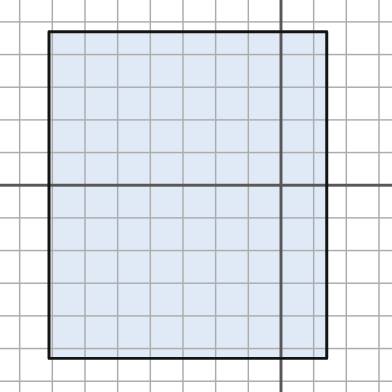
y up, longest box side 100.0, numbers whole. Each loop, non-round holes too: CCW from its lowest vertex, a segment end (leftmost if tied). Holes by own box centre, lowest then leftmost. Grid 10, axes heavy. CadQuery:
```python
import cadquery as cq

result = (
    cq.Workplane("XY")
    .moveTo(-71.0, -53.0)
    .lineTo(14.0, -53.0)
    .lineTo(14.0, 47.0)
    .lineTo(-71.0, 47.0)
    .close()
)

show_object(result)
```